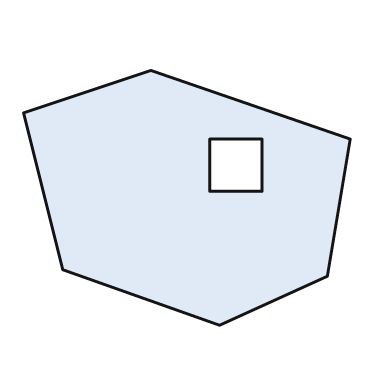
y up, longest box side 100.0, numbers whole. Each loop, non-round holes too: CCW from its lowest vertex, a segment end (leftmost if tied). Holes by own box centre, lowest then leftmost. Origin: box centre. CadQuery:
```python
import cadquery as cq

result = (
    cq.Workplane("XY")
    .moveTo(10.0, -39.0)
    .lineTo(43.0, -24.0)
    .lineTo(50.0, 18.0)
    .lineTo(-11.0, 39.0)
    .lineTo(-50.0, 26.0)
    .lineTo(-38.0, -22.0)
    .close()
    .moveTo(7.0, 2.0)
    .lineTo(23.0, 2.0)
    .lineTo(23.0, 18.0)
    .lineTo(7.0, 18.0)
    .close()
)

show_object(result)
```